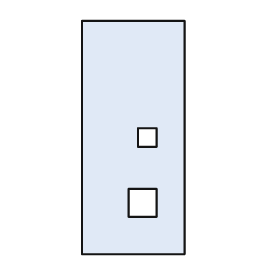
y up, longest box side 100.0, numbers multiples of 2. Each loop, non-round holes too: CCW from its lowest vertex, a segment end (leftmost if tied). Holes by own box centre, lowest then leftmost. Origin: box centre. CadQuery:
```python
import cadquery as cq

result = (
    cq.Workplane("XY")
    .moveTo(-22.0, -50.0)
    .lineTo(22.0, -50.0)
    .lineTo(22.0, 50.0)
    .lineTo(-22.0, 50.0)
    .close()
    .moveTo(-2.0, -34.0)
    .lineTo(10.0, -34.0)
    .lineTo(10.0, -22.0)
    .lineTo(-2.0, -22.0)
    .close()
    .moveTo(2.0, -4.0)
    .lineTo(10.0, -4.0)
    .lineTo(10.0, 4.0)
    .lineTo(2.0, 4.0)
    .close()
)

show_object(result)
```